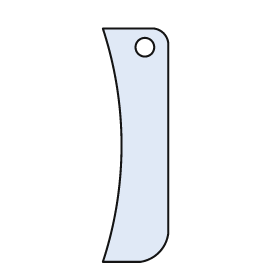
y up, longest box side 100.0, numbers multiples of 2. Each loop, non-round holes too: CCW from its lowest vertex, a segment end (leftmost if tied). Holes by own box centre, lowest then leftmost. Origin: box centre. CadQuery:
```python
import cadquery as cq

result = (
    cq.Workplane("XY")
    .moveTo(-14.0, -50.0)
    .lineTo(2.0, -50.0)
    .threePointArc((10.0, -46.0), (14.0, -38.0))
    .lineTo(14.0, 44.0)
    .threePointArc((12.0, 48.0), (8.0, 50.0))
    .lineTo(-14.0, 50.0)
    .threePointArc((-6.0, 0.0), (-14.0, -50.0))
    .close()
    .moveTo(4.0, 42.0)
    .circle(4.0)
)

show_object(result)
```